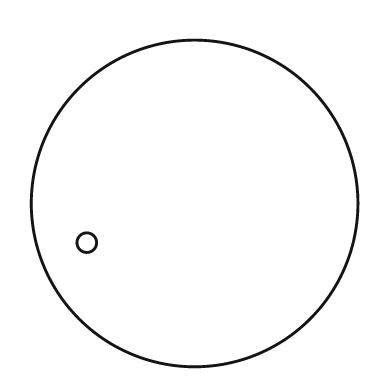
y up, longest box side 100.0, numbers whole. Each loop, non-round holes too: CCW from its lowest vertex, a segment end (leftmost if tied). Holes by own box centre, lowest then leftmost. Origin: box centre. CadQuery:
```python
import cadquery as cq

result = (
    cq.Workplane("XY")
    .moveTo(0.0, 0.0)
    .circle(50.0)
    .moveTo(-33.0, -12.0)
    .circle(3.0)
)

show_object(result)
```